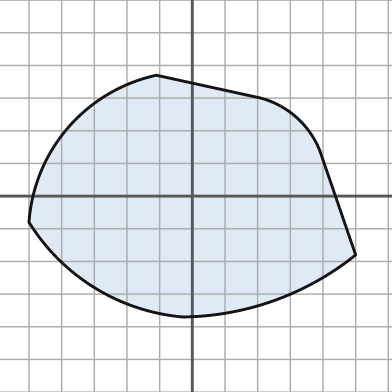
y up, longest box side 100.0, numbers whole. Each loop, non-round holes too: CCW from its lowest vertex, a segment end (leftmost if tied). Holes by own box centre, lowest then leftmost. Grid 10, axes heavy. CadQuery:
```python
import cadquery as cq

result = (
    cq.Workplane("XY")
    .moveTo(-3.0, -37.0)
    .threePointArc((25.0, -32.0), (50.0, -18.0))
    .lineTo(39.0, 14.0)
    .threePointArc((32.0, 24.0), (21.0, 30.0))
    .lineTo(-11.0, 37.0)
    .threePointArc((-38.0, 21.0), (-50.0, -8.0))
    .threePointArc((-30.0, -28.0), (-3.0, -37.0))
    .close()
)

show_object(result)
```